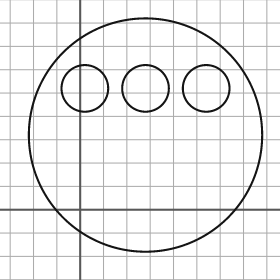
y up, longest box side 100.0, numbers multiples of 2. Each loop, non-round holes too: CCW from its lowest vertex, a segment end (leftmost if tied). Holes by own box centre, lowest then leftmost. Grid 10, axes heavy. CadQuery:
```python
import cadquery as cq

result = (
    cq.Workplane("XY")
    .moveTo(28.0, 32.0)
    .circle(50.0)
    .moveTo(2.0, 52.0)
    .circle(10.0)
    .moveTo(28.0, 52.0)
    .circle(10.0)
    .moveTo(54.0, 52.0)
    .circle(10.0)
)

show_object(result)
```